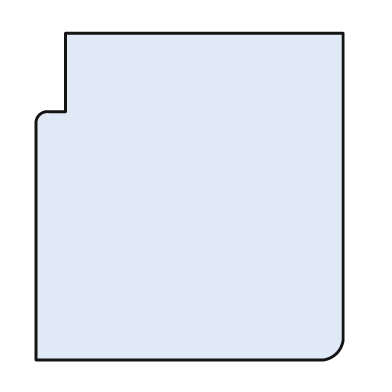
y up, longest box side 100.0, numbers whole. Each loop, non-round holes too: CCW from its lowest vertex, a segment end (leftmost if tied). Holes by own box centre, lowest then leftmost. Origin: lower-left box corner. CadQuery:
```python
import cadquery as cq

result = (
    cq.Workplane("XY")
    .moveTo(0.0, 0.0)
    .lineTo(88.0, 0.0)
    .threePointArc((92.0, 2.0), (94.0, 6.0))
    .lineTo(94.0, 100.0)
    .lineTo(9.0, 100.0)
    .lineTo(9.0, 76.0)
    .lineTo(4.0, 76.0)
    .threePointArc((1.0, 75.0), (0.0, 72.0))
    .close()
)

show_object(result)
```